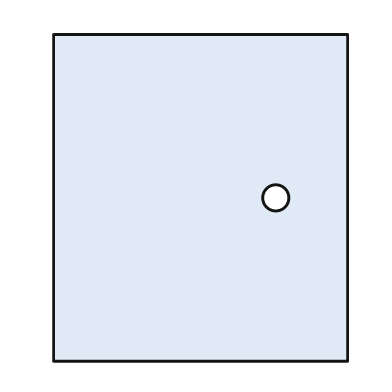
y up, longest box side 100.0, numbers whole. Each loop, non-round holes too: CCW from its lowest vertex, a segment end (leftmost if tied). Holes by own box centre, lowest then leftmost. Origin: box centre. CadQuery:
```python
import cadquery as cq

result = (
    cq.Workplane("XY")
    .moveTo(-45.0, -50.0)
    .lineTo(45.0, -50.0)
    .lineTo(45.0, 50.0)
    .lineTo(-45.0, 50.0)
    .close()
    .moveTo(23.0, 0.0)
    .circle(4.0)
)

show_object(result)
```